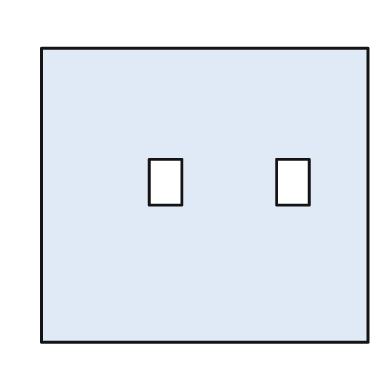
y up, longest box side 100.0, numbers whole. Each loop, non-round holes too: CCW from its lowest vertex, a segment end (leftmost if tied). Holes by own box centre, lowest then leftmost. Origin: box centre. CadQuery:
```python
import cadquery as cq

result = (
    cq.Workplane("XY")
    .moveTo(-50.0, -45.0)
    .lineTo(50.0, -45.0)
    .lineTo(50.0, 45.0)
    .lineTo(-50.0, 45.0)
    .close()
    .moveTo(-17.0, -3.0)
    .lineTo(-7.0, -3.0)
    .lineTo(-7.0, 11.0)
    .lineTo(-17.0, 11.0)
    .close()
    .moveTo(22.0, -3.0)
    .lineTo(32.0, -3.0)
    .lineTo(32.0, 11.0)
    .lineTo(22.0, 11.0)
    .close()
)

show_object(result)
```